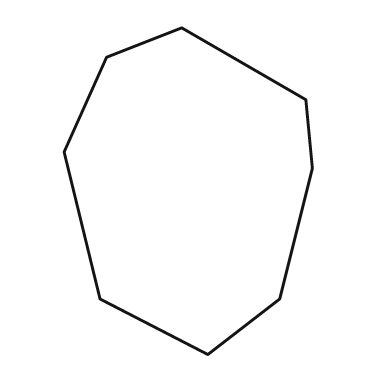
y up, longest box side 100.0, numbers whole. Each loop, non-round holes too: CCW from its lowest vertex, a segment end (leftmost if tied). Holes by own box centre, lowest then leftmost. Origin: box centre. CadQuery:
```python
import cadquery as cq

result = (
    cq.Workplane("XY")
    .moveTo(6.0, -50.0)
    .lineTo(28.0, -33.0)
    .lineTo(38.0, 7.0)
    .lineTo(36.0, 28.0)
    .lineTo(-2.0, 50.0)
    .lineTo(-25.0, 41.0)
    .lineTo(-38.0, 12.0)
    .lineTo(-27.0, -33.0)
    .close()
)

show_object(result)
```